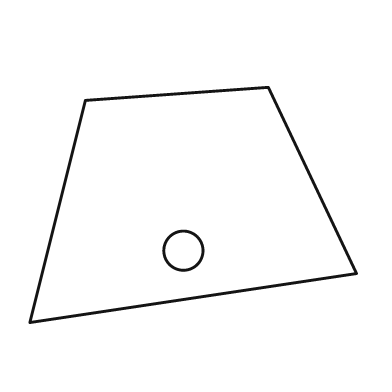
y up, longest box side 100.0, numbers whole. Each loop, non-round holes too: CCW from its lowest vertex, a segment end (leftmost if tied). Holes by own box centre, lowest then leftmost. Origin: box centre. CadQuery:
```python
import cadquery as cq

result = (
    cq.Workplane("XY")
    .moveTo(-50.0, -36.0)
    .lineTo(50.0, -21.0)
    .lineTo(23.0, 36.0)
    .lineTo(-33.0, 32.0)
    .close()
    .moveTo(-3.0, -14.0)
    .circle(6.0)
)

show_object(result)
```